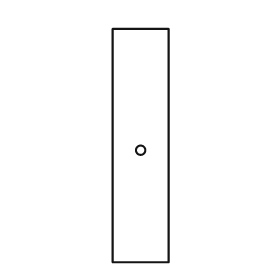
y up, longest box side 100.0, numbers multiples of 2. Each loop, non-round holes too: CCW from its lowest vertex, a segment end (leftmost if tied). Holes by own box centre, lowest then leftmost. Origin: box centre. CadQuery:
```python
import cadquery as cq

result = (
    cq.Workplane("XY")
    .moveTo(-12.0, -50.0)
    .lineTo(12.0, -50.0)
    .lineTo(12.0, 50.0)
    .lineTo(-12.0, 50.0)
    .close()
    .moveTo(0.0, -2.0)
    .circle(2.0)
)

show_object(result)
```